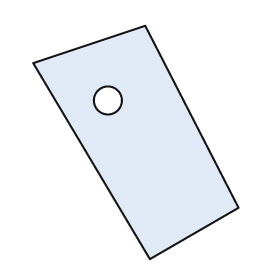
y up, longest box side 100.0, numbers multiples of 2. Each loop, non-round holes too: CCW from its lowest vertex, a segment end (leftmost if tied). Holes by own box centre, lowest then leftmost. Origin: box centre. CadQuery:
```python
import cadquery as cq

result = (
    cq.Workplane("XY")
    .moveTo(6.0, -50.0)
    .lineTo(44.0, -28.0)
    .lineTo(4.0, 50.0)
    .lineTo(-44.0, 34.0)
    .close()
    .moveTo(-12.0, 18.0)
    .circle(6.0)
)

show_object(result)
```